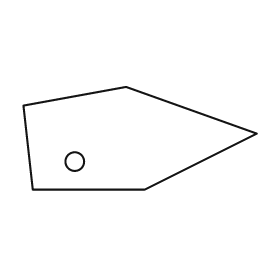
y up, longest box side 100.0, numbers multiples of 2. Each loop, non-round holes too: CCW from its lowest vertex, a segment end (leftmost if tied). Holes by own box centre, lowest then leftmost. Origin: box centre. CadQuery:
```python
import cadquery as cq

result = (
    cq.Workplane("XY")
    .moveTo(-46.0, -22.0)
    .lineTo(2.0, -22.0)
    .lineTo(50.0, 2.0)
    .lineTo(-6.0, 22.0)
    .lineTo(-50.0, 14.0)
    .close()
    .moveTo(-28.0, -10.0)
    .circle(4.0)
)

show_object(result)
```